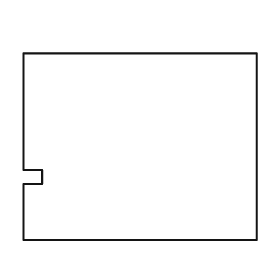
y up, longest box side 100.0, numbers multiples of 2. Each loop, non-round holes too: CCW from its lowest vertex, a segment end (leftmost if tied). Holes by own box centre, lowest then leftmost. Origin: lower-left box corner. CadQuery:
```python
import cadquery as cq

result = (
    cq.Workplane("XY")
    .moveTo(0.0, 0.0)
    .lineTo(100.0, 0.0)
    .lineTo(100.0, 80.0)
    .lineTo(0.0, 80.0)
    .lineTo(0.0, 30.0)
    .lineTo(8.0, 30.0)
    .lineTo(8.0, 24.0)
    .lineTo(0.0, 24.0)
    .close()
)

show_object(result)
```